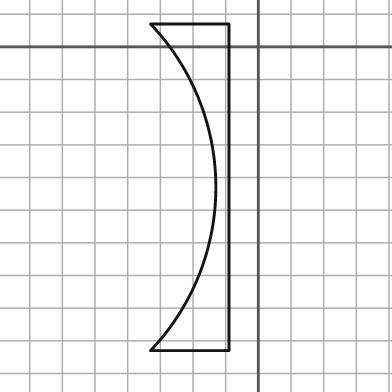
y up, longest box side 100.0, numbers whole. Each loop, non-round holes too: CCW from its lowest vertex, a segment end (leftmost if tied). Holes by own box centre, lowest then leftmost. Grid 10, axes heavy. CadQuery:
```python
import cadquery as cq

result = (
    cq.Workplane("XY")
    .moveTo(-33.0, -93.0)
    .lineTo(-9.0, -93.0)
    .lineTo(-9.0, 7.0)
    .lineTo(-33.0, 7.0)
    .threePointArc((-13.0, -43.0), (-33.0, -93.0))
    .close()
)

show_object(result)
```